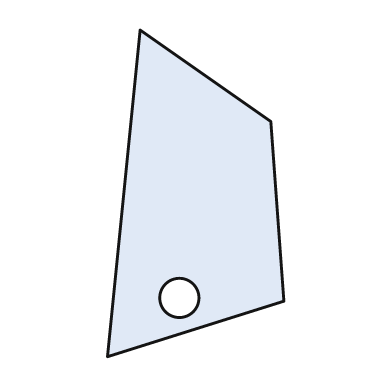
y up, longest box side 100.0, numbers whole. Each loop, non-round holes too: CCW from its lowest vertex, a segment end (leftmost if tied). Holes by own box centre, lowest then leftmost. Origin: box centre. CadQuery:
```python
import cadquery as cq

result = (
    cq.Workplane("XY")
    .moveTo(-27.0, -50.0)
    .lineTo(27.0, -33.0)
    .lineTo(23.0, 22.0)
    .lineTo(-17.0, 50.0)
    .close()
    .moveTo(-5.0, -32.0)
    .circle(6.0)
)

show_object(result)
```